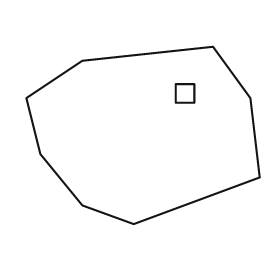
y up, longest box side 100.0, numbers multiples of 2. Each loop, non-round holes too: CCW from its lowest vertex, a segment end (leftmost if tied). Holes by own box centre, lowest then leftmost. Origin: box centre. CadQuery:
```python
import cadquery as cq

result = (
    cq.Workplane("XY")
    .moveTo(-4.0, -38.0)
    .lineTo(50.0, -18.0)
    .lineTo(46.0, 16.0)
    .lineTo(30.0, 38.0)
    .lineTo(-26.0, 32.0)
    .lineTo(-50.0, 16.0)
    .lineTo(-44.0, -8.0)
    .lineTo(-26.0, -30.0)
    .close()
    .moveTo(14.0, 14.0)
    .lineTo(22.0, 14.0)
    .lineTo(22.0, 22.0)
    .lineTo(14.0, 22.0)
    .close()
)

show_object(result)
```